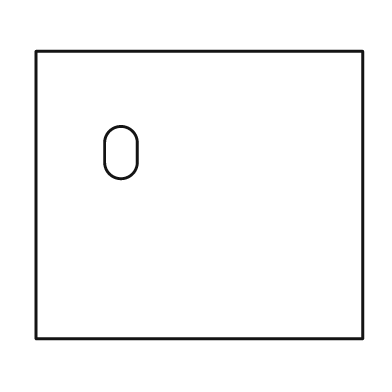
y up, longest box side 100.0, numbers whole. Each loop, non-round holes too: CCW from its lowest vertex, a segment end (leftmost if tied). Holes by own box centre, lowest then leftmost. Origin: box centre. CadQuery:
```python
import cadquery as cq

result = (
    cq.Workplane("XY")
    .moveTo(-50.0, -44.0)
    .lineTo(50.0, -44.0)
    .lineTo(50.0, 44.0)
    .lineTo(-50.0, 44.0)
    .close()
    .moveTo(-29.0, 10.0)
    .threePointArc((-24.0, 5.0), (-19.0, 10.0))
    .lineTo(-19.0, 16.0)
    .threePointArc((-24.0, 21.0), (-29.0, 16.0))
    .close()
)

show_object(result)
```